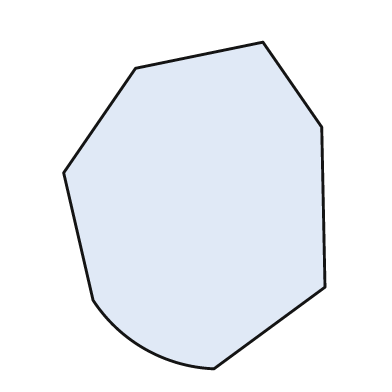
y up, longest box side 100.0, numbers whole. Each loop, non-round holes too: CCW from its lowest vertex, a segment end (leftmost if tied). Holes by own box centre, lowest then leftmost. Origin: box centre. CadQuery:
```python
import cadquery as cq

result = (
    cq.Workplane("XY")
    .moveTo(6.0, -50.0)
    .lineTo(40.0, -25.0)
    .lineTo(39.0, 24.0)
    .lineTo(21.0, 50.0)
    .lineTo(-18.0, 42.0)
    .lineTo(-40.0, 10.0)
    .lineTo(-31.0, -29.0)
    .threePointArc((-15.0, -44.0), (6.0, -50.0))
    .close()
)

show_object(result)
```